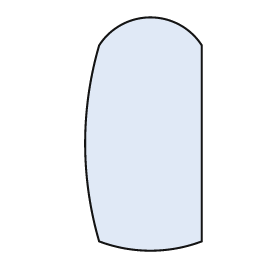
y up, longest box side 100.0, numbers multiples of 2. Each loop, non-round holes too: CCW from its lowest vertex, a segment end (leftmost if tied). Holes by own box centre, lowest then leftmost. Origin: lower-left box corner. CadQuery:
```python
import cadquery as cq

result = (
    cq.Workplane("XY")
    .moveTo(6.0, 4.0)
    .threePointArc((28.0, 0.0), (50.0, 4.0))
    .lineTo(50.0, 88.0)
    .threePointArc((28.0, 100.0), (6.0, 88.0))
    .threePointArc((0.0, 46.0), (6.0, 4.0))
    .close()
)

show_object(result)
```